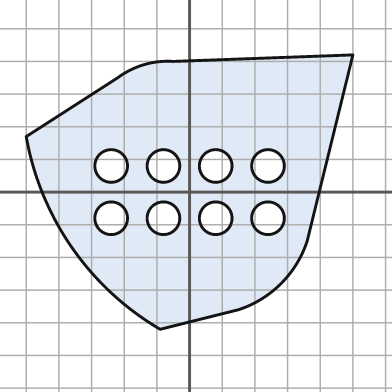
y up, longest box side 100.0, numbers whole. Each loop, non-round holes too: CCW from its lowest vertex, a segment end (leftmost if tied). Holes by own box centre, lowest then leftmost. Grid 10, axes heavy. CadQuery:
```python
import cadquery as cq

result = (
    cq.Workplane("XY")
    .moveTo(-9.0, -42.0)
    .lineTo(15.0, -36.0)
    .threePointArc((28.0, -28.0), (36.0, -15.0))
    .lineTo(50.0, 42.0)
    .lineTo(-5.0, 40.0)
    .threePointArc((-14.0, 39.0), (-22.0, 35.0))
    .lineTo(-50.0, 17.0)
    .threePointArc((-36.0, -17.0), (-9.0, -42.0))
    .close()
    .moveTo(-24.0, -8.0)
    .circle(5.0)
    .moveTo(-8.0, -8.0)
    .circle(5.0)
    .moveTo(8.0, -8.0)
    .circle(5.0)
    .moveTo(24.0, -8.0)
    .circle(5.0)
    .moveTo(-24.0, 8.0)
    .circle(5.0)
    .moveTo(-8.0, 8.0)
    .circle(5.0)
    .moveTo(8.0, 8.0)
    .circle(5.0)
    .moveTo(24.0, 8.0)
    .circle(5.0)
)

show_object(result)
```